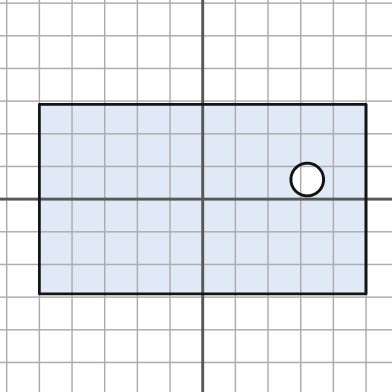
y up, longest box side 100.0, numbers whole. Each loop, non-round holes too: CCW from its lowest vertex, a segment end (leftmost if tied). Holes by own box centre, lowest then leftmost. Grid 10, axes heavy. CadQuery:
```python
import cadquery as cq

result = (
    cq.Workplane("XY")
    .moveTo(-50.0, -29.0)
    .lineTo(50.0, -29.0)
    .lineTo(50.0, 29.0)
    .lineTo(-50.0, 29.0)
    .close()
    .moveTo(32.0, 6.0)
    .circle(5.0)
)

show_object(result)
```